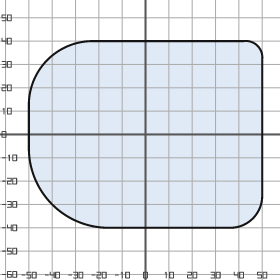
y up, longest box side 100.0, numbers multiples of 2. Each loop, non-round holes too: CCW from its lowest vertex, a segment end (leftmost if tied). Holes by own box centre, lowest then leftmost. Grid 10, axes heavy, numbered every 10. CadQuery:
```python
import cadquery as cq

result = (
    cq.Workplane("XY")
    .moveTo(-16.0, -40.0)
    .lineTo(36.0, -40.0)
    .threePointArc((46.0, -36.0), (50.0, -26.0))
    .lineTo(50.0, 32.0)
    .threePointArc((48.0, 38.0), (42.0, 40.0))
    .lineTo(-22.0, 40.0)
    .threePointArc((-42.0, 32.0), (-50.0, 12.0))
    .lineTo(-50.0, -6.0)
    .threePointArc((-40.0, -30.0), (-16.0, -40.0))
    .close()
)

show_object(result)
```